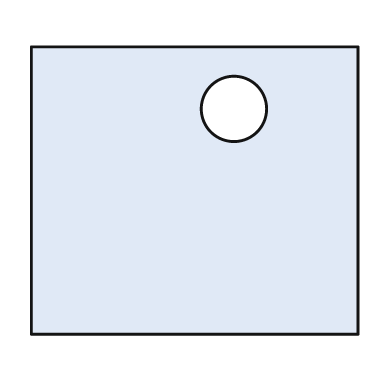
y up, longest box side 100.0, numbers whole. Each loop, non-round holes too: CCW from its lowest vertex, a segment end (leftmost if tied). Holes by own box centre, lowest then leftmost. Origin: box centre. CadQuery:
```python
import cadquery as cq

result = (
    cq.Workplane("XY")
    .moveTo(-50.0, -44.0)
    .lineTo(50.0, -44.0)
    .lineTo(50.0, 44.0)
    .lineTo(-50.0, 44.0)
    .close()
    .moveTo(12.0, 25.0)
    .circle(10.0)
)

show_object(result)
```